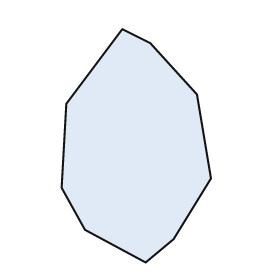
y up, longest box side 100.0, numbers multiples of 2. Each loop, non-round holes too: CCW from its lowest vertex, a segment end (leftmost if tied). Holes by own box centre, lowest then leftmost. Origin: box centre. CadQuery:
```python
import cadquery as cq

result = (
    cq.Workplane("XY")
    .moveTo(4.0, -50.0)
    .lineTo(16.0, -40.0)
    .lineTo(32.0, -14.0)
    .lineTo(26.0, 22.0)
    .lineTo(6.0, 44.0)
    .lineTo(-6.0, 50.0)
    .lineTo(-30.0, 18.0)
    .lineTo(-32.0, -18.0)
    .lineTo(-22.0, -36.0)
    .close()
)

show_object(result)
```